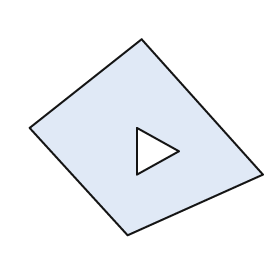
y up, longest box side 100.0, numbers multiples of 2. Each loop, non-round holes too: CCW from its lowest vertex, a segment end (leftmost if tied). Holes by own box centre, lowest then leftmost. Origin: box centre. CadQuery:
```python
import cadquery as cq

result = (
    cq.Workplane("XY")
    .moveTo(-8.0, -42.0)
    .lineTo(50.0, -16.0)
    .lineTo(-2.0, 42.0)
    .lineTo(-50.0, 4.0)
    .close()
    .moveTo(-4.0, -16.0)
    .lineTo(14.0, -6.0)
    .lineTo(-4.0, 4.0)
    .close()
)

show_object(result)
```